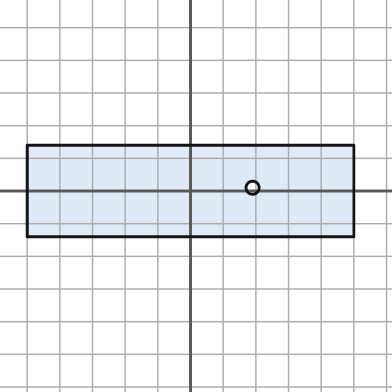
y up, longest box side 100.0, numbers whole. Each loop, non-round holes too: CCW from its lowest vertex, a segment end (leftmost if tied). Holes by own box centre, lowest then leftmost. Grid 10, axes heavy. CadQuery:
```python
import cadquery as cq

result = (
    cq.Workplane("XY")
    .moveTo(-50.0, -14.0)
    .lineTo(50.0, -14.0)
    .lineTo(50.0, 14.0)
    .lineTo(-50.0, 14.0)
    .close()
    .moveTo(19.0, 1.0)
    .circle(2.0)
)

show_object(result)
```